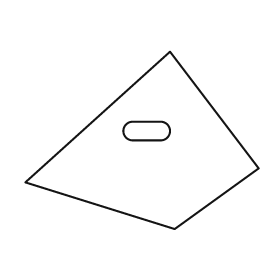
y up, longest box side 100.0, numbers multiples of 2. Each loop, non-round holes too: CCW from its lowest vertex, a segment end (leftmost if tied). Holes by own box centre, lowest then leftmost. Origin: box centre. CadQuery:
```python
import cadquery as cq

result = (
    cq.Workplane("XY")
    .moveTo(14.0, -38.0)
    .lineTo(50.0, -12.0)
    .lineTo(12.0, 38.0)
    .lineTo(-50.0, -18.0)
    .close()
    .moveTo(-4.0, 0.0)
    .lineTo(8.0, 0.0)
    .threePointArc((12.0, 4.0), (8.0, 8.0))
    .lineTo(-4.0, 8.0)
    .threePointArc((-8.0, 4.0), (-4.0, 0.0))
    .close()
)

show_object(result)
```